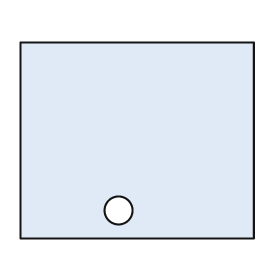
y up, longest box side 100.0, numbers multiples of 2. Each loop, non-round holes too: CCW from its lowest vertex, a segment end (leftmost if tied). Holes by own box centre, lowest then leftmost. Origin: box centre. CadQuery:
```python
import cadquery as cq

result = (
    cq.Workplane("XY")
    .moveTo(-50.0, -42.0)
    .lineTo(50.0, -42.0)
    .lineTo(50.0, 42.0)
    .lineTo(-50.0, 42.0)
    .close()
    .moveTo(-8.0, -30.0)
    .circle(6.0)
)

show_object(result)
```